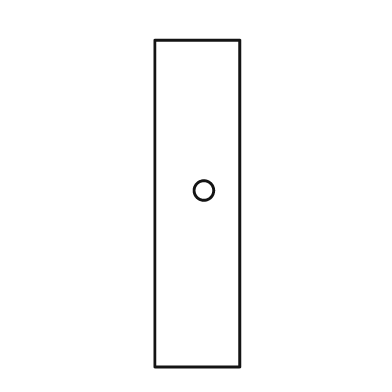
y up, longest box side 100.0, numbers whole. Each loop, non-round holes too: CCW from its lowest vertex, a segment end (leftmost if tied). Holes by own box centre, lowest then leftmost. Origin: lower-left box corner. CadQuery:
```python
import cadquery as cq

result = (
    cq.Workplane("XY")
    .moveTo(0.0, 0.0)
    .lineTo(26.0, 0.0)
    .lineTo(26.0, 100.0)
    .lineTo(0.0, 100.0)
    .close()
    .moveTo(15.0, 54.0)
    .circle(3.0)
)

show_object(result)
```